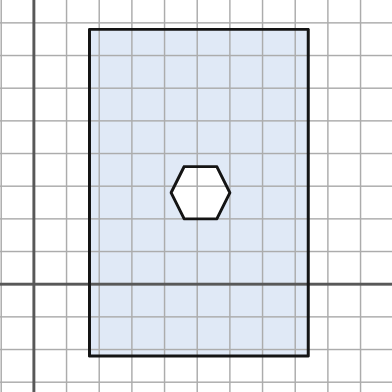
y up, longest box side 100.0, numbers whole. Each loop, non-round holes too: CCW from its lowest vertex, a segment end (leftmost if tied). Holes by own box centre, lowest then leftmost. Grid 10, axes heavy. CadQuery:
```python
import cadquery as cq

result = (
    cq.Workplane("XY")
    .moveTo(17.0, -22.0)
    .lineTo(84.0, -22.0)
    .lineTo(84.0, 78.0)
    .lineTo(17.0, 78.0)
    .close()
    .moveTo(46.0, 20.0)
    .lineTo(56.0, 20.0)
    .lineTo(60.0, 28.0)
    .lineTo(56.0, 36.0)
    .lineTo(46.0, 36.0)
    .lineTo(42.0, 28.0)
    .close()
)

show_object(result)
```